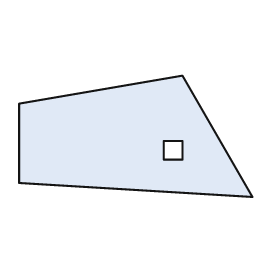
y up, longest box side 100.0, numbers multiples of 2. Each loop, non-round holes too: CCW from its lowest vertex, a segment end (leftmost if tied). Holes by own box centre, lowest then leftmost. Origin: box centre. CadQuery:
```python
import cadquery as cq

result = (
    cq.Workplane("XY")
    .moveTo(50.0, -26.0)
    .lineTo(20.0, 26.0)
    .lineTo(-50.0, 14.0)
    .lineTo(-50.0, -20.0)
    .close()
    .moveTo(12.0, -10.0)
    .lineTo(20.0, -10.0)
    .lineTo(20.0, -2.0)
    .lineTo(12.0, -2.0)
    .close()
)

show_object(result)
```